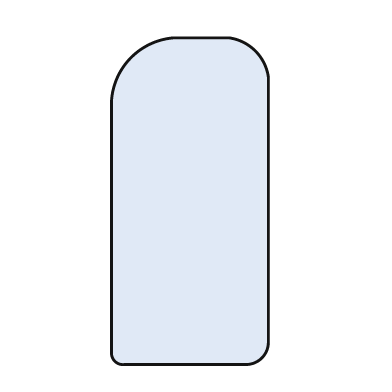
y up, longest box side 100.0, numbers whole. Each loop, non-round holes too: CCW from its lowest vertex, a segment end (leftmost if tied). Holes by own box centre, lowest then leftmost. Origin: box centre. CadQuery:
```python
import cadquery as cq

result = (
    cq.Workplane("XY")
    .moveTo(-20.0, -50.0)
    .lineTo(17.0, -50.0)
    .threePointArc((22.0, -48.0), (24.0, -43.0))
    .lineTo(24.0, 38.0)
    .threePointArc((20.0, 46.0), (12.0, 50.0))
    .lineTo(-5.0, 50.0)
    .threePointArc((-18.0, 44.0), (-24.0, 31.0))
    .lineTo(-24.0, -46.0)
    .threePointArc((-23.0, -49.0), (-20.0, -50.0))
    .close()
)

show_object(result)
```